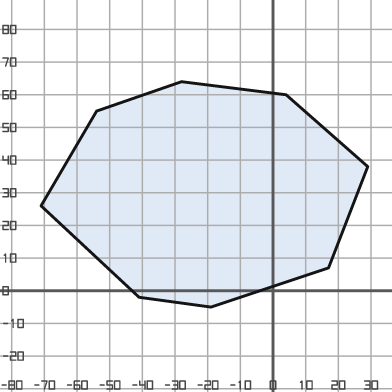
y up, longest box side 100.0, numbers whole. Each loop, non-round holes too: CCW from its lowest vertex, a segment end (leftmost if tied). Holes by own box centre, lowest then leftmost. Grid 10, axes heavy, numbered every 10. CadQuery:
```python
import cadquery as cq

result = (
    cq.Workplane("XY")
    .moveTo(-19.0, -5.0)
    .lineTo(17.0, 7.0)
    .lineTo(29.0, 38.0)
    .lineTo(4.0, 60.0)
    .lineTo(-28.0, 64.0)
    .lineTo(-54.0, 55.0)
    .lineTo(-71.0, 26.0)
    .lineTo(-41.0, -2.0)
    .close()
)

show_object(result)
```